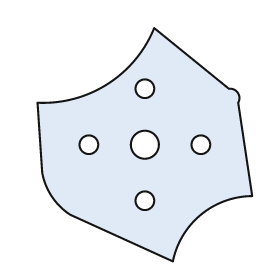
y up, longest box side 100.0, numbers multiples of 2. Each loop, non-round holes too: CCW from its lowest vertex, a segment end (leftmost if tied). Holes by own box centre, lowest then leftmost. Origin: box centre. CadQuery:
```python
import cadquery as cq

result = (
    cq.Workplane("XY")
    .moveTo(12.0, -50.0)
    .threePointArc((24.0, -30.0), (46.0, -22.0))
    .lineTo(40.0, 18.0)
    .threePointArc((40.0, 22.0), (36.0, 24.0))
    .lineTo(4.0, 50.0)
    .threePointArc((-16.0, 26.0), (-46.0, 18.0))
    .lineTo(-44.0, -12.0)
    .threePointArc((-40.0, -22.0), (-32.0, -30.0))
    .close()
    .moveTo(0.0, -24.0)
    .circle(4.0)
    .moveTo(-24.0, 0.0)
    .circle(4.0)
    .moveTo(0.0, 0.0)
    .circle(6.0)
    .moveTo(24.0, 0.0)
    .circle(4.0)
    .moveTo(0.0, 24.0)
    .circle(4.0)
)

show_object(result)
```